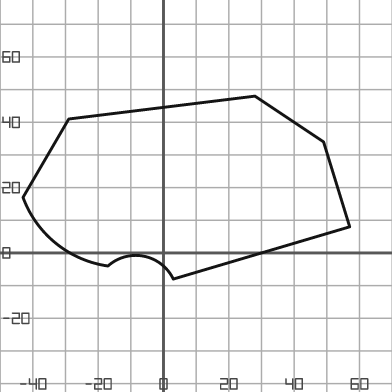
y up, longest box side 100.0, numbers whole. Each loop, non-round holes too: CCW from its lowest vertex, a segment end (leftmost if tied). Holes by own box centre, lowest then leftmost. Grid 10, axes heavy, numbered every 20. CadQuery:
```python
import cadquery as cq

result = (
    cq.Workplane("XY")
    .moveTo(3.0, -8.0)
    .lineTo(57.0, 8.0)
    .lineTo(49.0, 34.0)
    .lineTo(28.0, 48.0)
    .lineTo(-29.0, 41.0)
    .lineTo(-43.0, 17.0)
    .threePointArc((-33.0, 3.0), (-17.0, -4.0))
    .threePointArc((-6.0, -1.0), (3.0, -8.0))
    .close()
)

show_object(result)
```